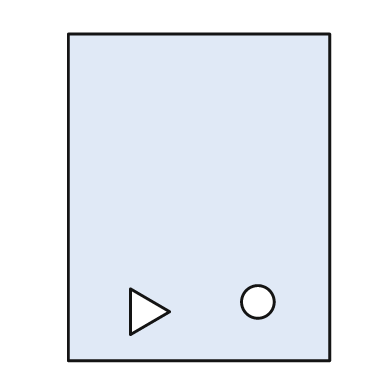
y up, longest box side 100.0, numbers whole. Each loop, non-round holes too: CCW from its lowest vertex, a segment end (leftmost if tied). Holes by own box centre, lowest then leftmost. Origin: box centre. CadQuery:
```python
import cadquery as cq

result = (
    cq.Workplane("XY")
    .moveTo(-40.0, -50.0)
    .lineTo(40.0, -50.0)
    .lineTo(40.0, 50.0)
    .lineTo(-40.0, 50.0)
    .close()
    .moveTo(-21.0, -42.0)
    .lineTo(-9.0, -35.0)
    .lineTo(-21.0, -28.0)
    .close()
    .moveTo(18.0, -32.0)
    .circle(5.0)
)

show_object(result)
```